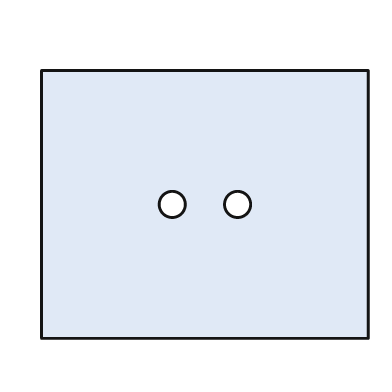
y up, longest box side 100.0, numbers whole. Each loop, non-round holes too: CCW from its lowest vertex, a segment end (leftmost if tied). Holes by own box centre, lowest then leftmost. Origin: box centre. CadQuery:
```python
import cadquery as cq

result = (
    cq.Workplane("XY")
    .moveTo(-50.0, -41.0)
    .lineTo(50.0, -41.0)
    .lineTo(50.0, 41.0)
    .lineTo(-50.0, 41.0)
    .close()
    .moveTo(-10.0, 0.0)
    .circle(4.0)
    .moveTo(10.0, 0.0)
    .circle(4.0)
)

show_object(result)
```